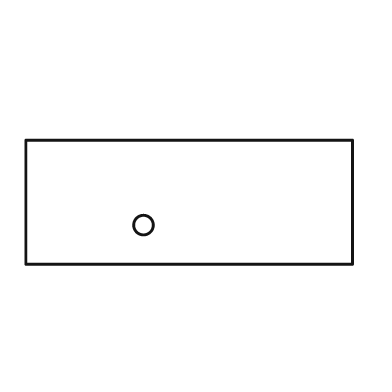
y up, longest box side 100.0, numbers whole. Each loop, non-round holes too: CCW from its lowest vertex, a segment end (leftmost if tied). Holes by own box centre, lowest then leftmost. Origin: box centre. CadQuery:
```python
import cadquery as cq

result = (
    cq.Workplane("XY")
    .moveTo(-50.0, -19.0)
    .lineTo(50.0, -19.0)
    .lineTo(50.0, 19.0)
    .lineTo(-50.0, 19.0)
    .close()
    .moveTo(-14.0, -7.0)
    .circle(3.0)
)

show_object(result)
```